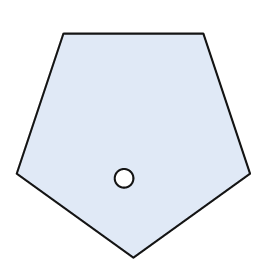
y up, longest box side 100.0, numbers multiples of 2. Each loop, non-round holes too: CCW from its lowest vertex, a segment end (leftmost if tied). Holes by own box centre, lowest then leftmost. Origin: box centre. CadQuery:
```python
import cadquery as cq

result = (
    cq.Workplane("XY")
    .moveTo(0.0, -48.0)
    .lineTo(50.0, -12.0)
    .lineTo(30.0, 48.0)
    .lineTo(-30.0, 48.0)
    .lineTo(-50.0, -12.0)
    .close()
    .moveTo(-4.0, -14.0)
    .circle(4.0)
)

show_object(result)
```